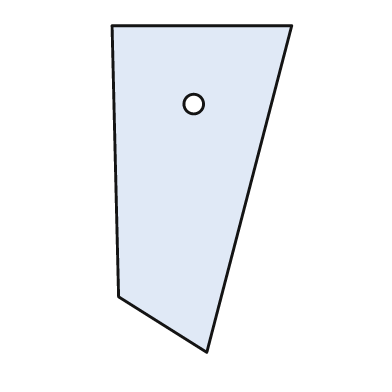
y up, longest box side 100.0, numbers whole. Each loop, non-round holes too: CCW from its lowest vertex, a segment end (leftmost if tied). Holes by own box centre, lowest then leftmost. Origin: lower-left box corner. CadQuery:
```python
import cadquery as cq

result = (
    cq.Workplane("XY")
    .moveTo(29.0, 0.0)
    .lineTo(55.0, 100.0)
    .lineTo(0.0, 100.0)
    .lineTo(2.0, 17.0)
    .close()
    .moveTo(25.0, 76.0)
    .circle(3.0)
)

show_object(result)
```